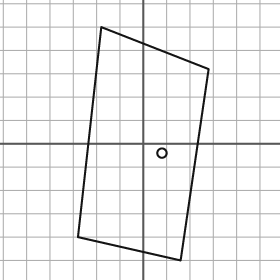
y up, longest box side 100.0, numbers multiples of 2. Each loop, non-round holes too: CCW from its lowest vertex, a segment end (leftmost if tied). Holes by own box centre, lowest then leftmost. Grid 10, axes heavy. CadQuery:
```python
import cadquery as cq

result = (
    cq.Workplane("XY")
    .moveTo(16.0, -50.0)
    .lineTo(28.0, 32.0)
    .lineTo(-18.0, 50.0)
    .lineTo(-28.0, -40.0)
    .close()
    .moveTo(8.0, -4.0)
    .circle(2.0)
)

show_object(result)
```